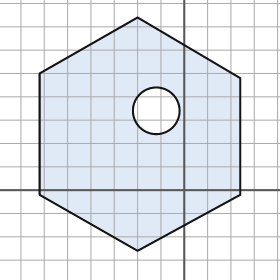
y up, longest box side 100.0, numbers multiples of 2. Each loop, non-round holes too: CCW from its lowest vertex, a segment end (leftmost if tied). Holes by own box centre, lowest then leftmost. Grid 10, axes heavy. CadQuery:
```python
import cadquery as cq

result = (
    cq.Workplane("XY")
    .moveTo(-20.0, -26.0)
    .lineTo(24.0, -2.0)
    .lineTo(24.0, 48.0)
    .lineTo(-20.0, 74.0)
    .lineTo(-62.0, 50.0)
    .lineTo(-62.0, -2.0)
    .close()
    .moveTo(-12.0, 34.0)
    .circle(10.0)
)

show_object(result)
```